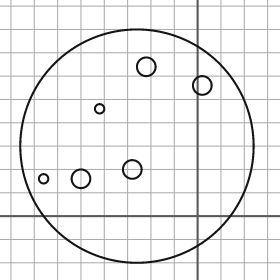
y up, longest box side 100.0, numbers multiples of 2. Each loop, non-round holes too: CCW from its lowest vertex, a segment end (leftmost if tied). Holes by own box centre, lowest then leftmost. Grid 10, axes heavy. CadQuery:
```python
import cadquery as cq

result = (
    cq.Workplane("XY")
    .moveTo(-26.0, 30.0)
    .circle(50.0)
    .moveTo(-66.0, 16.0)
    .circle(2.0)
    .moveTo(-50.0, 16.0)
    .circle(4.0)
    .moveTo(-28.0, 20.0)
    .circle(4.0)
    .moveTo(-42.0, 46.0)
    .circle(2.0)
    .moveTo(2.0, 56.0)
    .circle(4.0)
    .moveTo(-22.0, 64.0)
    .circle(4.0)
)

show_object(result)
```